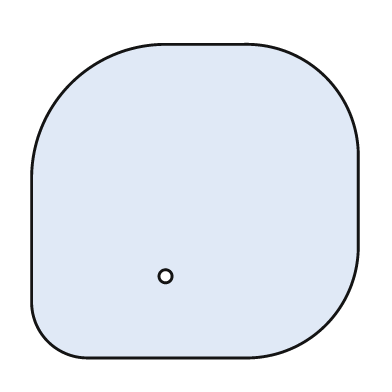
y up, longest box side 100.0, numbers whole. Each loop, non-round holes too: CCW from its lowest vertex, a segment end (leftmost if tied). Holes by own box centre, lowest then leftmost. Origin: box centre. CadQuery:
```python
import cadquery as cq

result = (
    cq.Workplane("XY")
    .moveTo(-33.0, -48.0)
    .lineTo(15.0, -48.0)
    .threePointArc((40.0, -38.0), (50.0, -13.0))
    .lineTo(50.0, 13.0)
    .threePointArc((40.0, 38.0), (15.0, 48.0))
    .lineTo(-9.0, 48.0)
    .threePointArc((-38.0, 36.0), (-50.0, 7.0))
    .lineTo(-50.0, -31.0)
    .threePointArc((-45.0, -43.0), (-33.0, -48.0))
    .close()
    .moveTo(-9.0, -23.0)
    .circle(2.0)
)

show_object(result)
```